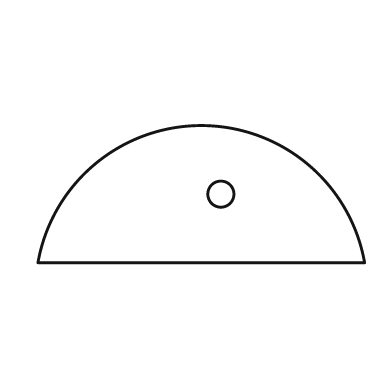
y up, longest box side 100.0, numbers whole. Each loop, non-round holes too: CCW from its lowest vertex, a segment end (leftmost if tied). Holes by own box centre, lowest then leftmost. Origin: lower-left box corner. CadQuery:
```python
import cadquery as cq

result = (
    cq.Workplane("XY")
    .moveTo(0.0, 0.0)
    .lineTo(100.0, 0.0)
    .threePointArc((50.0, 42.0), (0.0, 0.0))
    .close()
    .moveTo(56.0, 21.0)
    .circle(4.0)
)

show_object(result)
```